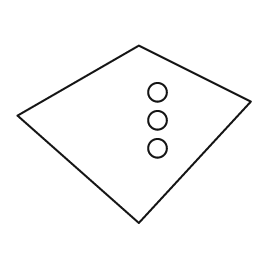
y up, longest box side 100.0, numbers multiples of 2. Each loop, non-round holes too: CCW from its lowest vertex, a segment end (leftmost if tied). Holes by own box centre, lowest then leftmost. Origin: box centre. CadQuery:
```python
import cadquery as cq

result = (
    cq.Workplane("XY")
    .moveTo(2.0, -38.0)
    .lineTo(50.0, 14.0)
    .lineTo(2.0, 38.0)
    .lineTo(-50.0, 8.0)
    .close()
    .moveTo(10.0, -6.0)
    .circle(4.0)
    .moveTo(10.0, 6.0)
    .circle(4.0)
    .moveTo(10.0, 18.0)
    .circle(4.0)
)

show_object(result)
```